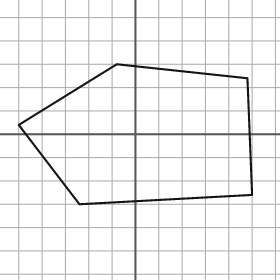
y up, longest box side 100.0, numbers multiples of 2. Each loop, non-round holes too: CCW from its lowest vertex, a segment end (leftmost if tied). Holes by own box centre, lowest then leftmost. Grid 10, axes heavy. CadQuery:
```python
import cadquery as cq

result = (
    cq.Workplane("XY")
    .moveTo(-24.0, -30.0)
    .lineTo(50.0, -26.0)
    .lineTo(48.0, 24.0)
    .lineTo(-8.0, 30.0)
    .lineTo(-50.0, 4.0)
    .close()
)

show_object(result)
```